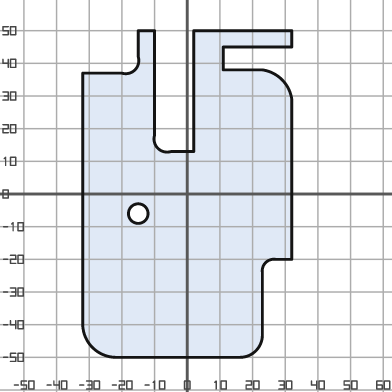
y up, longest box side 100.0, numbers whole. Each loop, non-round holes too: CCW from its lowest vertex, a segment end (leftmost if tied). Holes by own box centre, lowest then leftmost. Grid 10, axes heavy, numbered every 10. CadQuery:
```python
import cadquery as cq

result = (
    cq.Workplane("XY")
    .moveTo(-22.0, -50.0)
    .lineTo(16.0, -50.0)
    .threePointArc((21.0, -48.0), (23.0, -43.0))
    .lineTo(23.0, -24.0)
    .threePointArc((24.0, -21.0), (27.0, -20.0))
    .lineTo(32.0, -20.0)
    .lineTo(32.0, 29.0)
    .threePointArc((29.0, 35.0), (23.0, 38.0))
    .lineTo(11.0, 38.0)
    .lineTo(11.0, 45.0)
    .lineTo(32.0, 45.0)
    .lineTo(32.0, 50.0)
    .lineTo(2.0, 50.0)
    .lineTo(2.0, 13.0)
    .lineTo(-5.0, 13.0)
    .threePointArc((-9.0, 14.0), (-10.0, 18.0))
    .lineTo(-10.0, 50.0)
    .lineTo(-15.0, 50.0)
    .lineTo(-15.0, 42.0)
    .threePointArc((-16.0, 38.0), (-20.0, 37.0))
    .lineTo(-32.0, 37.0)
    .lineTo(-32.0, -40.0)
    .threePointArc((-29.0, -47.0), (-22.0, -50.0))
    .close()
    .moveTo(-15.0, -6.0)
    .circle(3.0)
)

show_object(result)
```